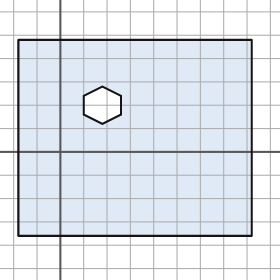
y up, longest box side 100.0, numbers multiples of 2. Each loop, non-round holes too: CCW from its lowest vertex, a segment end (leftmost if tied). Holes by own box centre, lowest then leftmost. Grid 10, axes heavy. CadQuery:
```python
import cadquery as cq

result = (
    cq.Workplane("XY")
    .moveTo(-18.0, -36.0)
    .lineTo(82.0, -36.0)
    .lineTo(82.0, 48.0)
    .lineTo(-18.0, 48.0)
    .close()
    .moveTo(18.0, 12.0)
    .lineTo(26.0, 16.0)
    .lineTo(26.0, 24.0)
    .lineTo(18.0, 28.0)
    .lineTo(10.0, 24.0)
    .lineTo(10.0, 16.0)
    .close()
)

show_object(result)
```